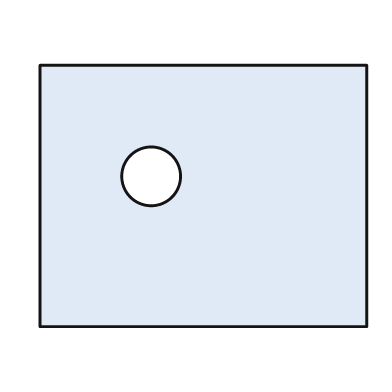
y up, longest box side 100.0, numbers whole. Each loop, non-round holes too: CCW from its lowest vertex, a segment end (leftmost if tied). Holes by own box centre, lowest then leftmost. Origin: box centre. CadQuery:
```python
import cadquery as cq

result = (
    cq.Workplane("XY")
    .moveTo(-50.0, -40.0)
    .lineTo(50.0, -40.0)
    .lineTo(50.0, 40.0)
    .lineTo(-50.0, 40.0)
    .close()
    .moveTo(-16.0, 6.0)
    .circle(9.0)
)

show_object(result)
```